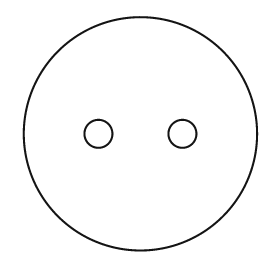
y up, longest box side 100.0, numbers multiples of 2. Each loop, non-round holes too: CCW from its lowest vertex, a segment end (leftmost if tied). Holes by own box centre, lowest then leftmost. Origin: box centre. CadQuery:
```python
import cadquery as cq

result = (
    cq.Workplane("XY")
    .moveTo(0.0, 0.0)
    .circle(50.0)
    .moveTo(-18.0, 0.0)
    .circle(6.0)
    .moveTo(18.0, 0.0)
    .circle(6.0)
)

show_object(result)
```